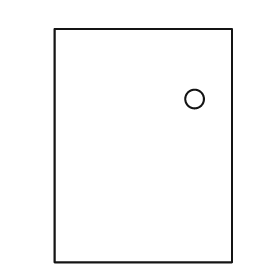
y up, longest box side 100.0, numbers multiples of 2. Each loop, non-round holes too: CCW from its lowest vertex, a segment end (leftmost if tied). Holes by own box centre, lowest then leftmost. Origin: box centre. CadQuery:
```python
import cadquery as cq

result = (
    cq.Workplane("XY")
    .moveTo(-38.0, -50.0)
    .lineTo(38.0, -50.0)
    .lineTo(38.0, 50.0)
    .lineTo(-38.0, 50.0)
    .close()
    .moveTo(22.0, 20.0)
    .circle(4.0)
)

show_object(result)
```